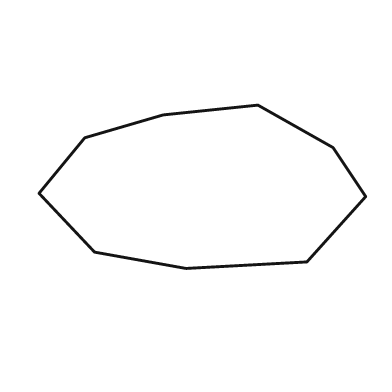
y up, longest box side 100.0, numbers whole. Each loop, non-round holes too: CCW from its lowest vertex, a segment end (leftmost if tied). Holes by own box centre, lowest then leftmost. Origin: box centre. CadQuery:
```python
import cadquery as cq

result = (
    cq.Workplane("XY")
    .moveTo(-5.0, -25.0)
    .lineTo(32.0, -23.0)
    .lineTo(50.0, -3.0)
    .lineTo(40.0, 12.0)
    .lineTo(17.0, 25.0)
    .lineTo(-12.0, 22.0)
    .lineTo(-36.0, 15.0)
    .lineTo(-50.0, -2.0)
    .lineTo(-33.0, -20.0)
    .close()
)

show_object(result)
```